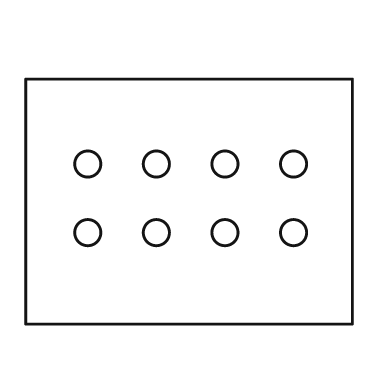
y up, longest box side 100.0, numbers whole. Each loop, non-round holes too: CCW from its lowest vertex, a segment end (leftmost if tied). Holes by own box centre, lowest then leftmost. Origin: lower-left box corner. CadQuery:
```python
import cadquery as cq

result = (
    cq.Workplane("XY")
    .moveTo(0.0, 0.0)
    .lineTo(100.0, 0.0)
    .lineTo(100.0, 75.0)
    .lineTo(0.0, 75.0)
    .close()
    .moveTo(19.0, 28.0)
    .circle(4.0)
    .moveTo(40.0, 28.0)
    .circle(4.0)
    .moveTo(61.0, 28.0)
    .circle(4.0)
    .moveTo(82.0, 28.0)
    .circle(4.0)
    .moveTo(19.0, 49.0)
    .circle(4.0)
    .moveTo(40.0, 49.0)
    .circle(4.0)
    .moveTo(61.0, 49.0)
    .circle(4.0)
    .moveTo(82.0, 49.0)
    .circle(4.0)
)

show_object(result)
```